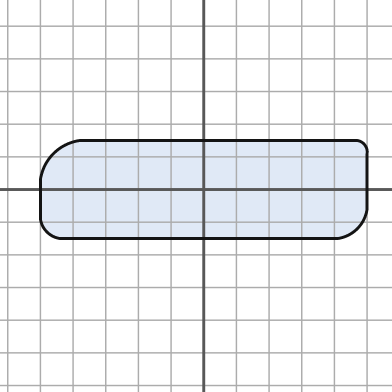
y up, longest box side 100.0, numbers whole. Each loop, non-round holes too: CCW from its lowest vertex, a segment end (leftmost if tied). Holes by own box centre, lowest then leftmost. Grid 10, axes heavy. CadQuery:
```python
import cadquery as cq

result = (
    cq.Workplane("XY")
    .moveTo(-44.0, -15.0)
    .lineTo(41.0, -15.0)
    .threePointArc((47.0, -12.0), (50.0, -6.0))
    .lineTo(50.0, 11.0)
    .threePointArc((49.0, 14.0), (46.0, 15.0))
    .lineTo(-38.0, 15.0)
    .threePointArc((-46.0, 11.0), (-50.0, 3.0))
    .lineTo(-50.0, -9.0)
    .threePointArc((-48.0, -13.0), (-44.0, -15.0))
    .close()
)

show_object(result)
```